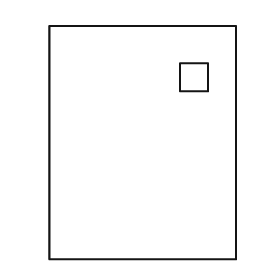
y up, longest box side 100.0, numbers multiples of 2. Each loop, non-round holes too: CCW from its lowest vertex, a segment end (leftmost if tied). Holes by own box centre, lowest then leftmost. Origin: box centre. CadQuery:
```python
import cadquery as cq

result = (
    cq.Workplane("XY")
    .moveTo(-40.0, -50.0)
    .lineTo(40.0, -50.0)
    .lineTo(40.0, 50.0)
    .lineTo(-40.0, 50.0)
    .close()
    .moveTo(16.0, 22.0)
    .lineTo(28.0, 22.0)
    .lineTo(28.0, 34.0)
    .lineTo(16.0, 34.0)
    .close()
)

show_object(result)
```